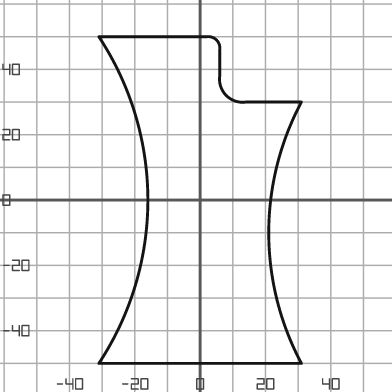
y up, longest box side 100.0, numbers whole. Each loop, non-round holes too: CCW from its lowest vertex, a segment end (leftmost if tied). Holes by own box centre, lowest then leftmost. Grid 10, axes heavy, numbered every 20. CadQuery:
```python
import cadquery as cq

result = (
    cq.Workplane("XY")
    .moveTo(-31.0, -50.0)
    .lineTo(31.0, -50.0)
    .threePointArc((21.0, -10.0), (31.0, 30.0))
    .lineTo(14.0, 30.0)
    .threePointArc((8.0, 32.0), (6.0, 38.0))
    .lineTo(6.0, 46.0)
    .threePointArc((5.0, 49.0), (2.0, 50.0))
    .lineTo(-31.0, 50.0)
    .threePointArc((-16.0, 0.0), (-31.0, -50.0))
    .close()
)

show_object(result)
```